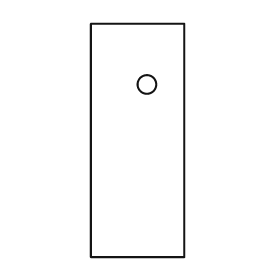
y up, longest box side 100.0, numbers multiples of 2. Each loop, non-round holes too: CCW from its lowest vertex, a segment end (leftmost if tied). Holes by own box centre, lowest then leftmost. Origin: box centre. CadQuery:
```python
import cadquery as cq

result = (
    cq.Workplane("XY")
    .moveTo(-20.0, -50.0)
    .lineTo(20.0, -50.0)
    .lineTo(20.0, 50.0)
    .lineTo(-20.0, 50.0)
    .close()
    .moveTo(4.0, 24.0)
    .circle(4.0)
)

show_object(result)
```